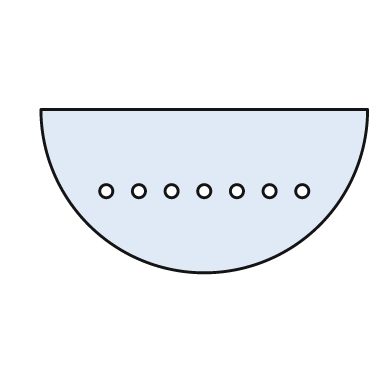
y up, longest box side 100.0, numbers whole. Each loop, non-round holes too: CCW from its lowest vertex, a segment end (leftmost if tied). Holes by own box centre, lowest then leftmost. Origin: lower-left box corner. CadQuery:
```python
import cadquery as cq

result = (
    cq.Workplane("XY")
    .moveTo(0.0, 50.0)
    .threePointArc((50.0, 0.0), (100.0, 50.0))
    .close()
    .moveTo(20.0, 25.0)
    .circle(2.0)
    .moveTo(30.0, 25.0)
    .circle(2.0)
    .moveTo(40.0, 25.0)
    .circle(2.0)
    .moveTo(50.0, 25.0)
    .circle(2.0)
    .moveTo(60.0, 25.0)
    .circle(2.0)
    .moveTo(70.0, 25.0)
    .circle(2.0)
    .moveTo(80.0, 25.0)
    .circle(2.0)
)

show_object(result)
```